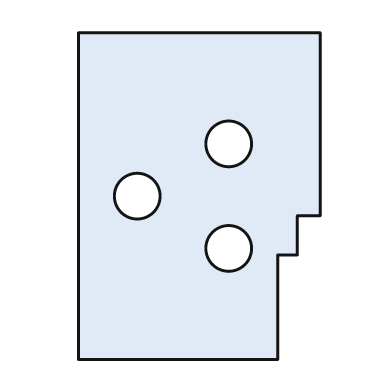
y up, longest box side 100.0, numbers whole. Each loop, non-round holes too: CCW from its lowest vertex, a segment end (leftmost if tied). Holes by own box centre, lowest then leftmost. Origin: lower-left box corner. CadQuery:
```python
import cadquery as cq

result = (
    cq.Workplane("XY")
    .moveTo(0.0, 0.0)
    .lineTo(61.0, 0.0)
    .lineTo(61.0, 32.0)
    .lineTo(67.0, 32.0)
    .lineTo(67.0, 44.0)
    .lineTo(74.0, 44.0)
    .lineTo(74.0, 100.0)
    .lineTo(0.0, 100.0)
    .close()
    .moveTo(46.0, 34.0)
    .circle(7.0)
    .moveTo(18.0, 50.0)
    .circle(7.0)
    .moveTo(46.0, 66.0)
    .circle(7.0)
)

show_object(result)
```